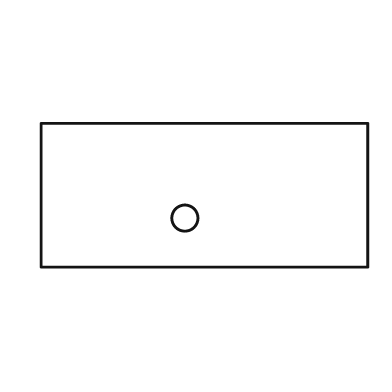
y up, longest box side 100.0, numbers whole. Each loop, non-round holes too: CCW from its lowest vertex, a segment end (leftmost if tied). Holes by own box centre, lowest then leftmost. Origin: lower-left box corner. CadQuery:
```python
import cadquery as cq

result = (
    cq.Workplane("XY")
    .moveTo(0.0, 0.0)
    .lineTo(100.0, 0.0)
    .lineTo(100.0, 44.0)
    .lineTo(0.0, 44.0)
    .close()
    .moveTo(44.0, 15.0)
    .circle(4.0)
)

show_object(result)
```